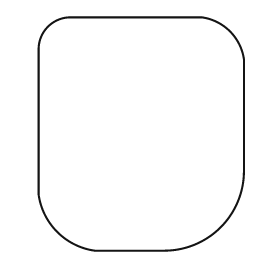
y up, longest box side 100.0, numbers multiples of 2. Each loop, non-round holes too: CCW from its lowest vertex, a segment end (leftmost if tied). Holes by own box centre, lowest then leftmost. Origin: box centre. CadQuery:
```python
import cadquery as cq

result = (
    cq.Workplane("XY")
    .moveTo(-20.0, -50.0)
    .lineTo(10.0, -50.0)
    .threePointArc((34.0, -40.0), (44.0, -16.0))
    .lineTo(44.0, 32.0)
    .threePointArc((38.0, 44.0), (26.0, 50.0))
    .lineTo(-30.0, 50.0)
    .threePointArc((-40.0, 46.0), (-44.0, 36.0))
    .lineTo(-44.0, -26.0)
    .threePointArc((-36.0, -42.0), (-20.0, -50.0))
    .close()
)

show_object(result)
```